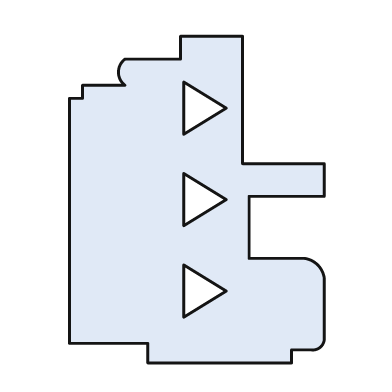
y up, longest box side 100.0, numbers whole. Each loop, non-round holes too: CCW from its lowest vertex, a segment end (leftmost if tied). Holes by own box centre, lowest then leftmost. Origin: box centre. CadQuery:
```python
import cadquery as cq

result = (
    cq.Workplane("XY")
    .moveTo(-15.0, -50.0)
    .lineTo(29.0, -50.0)
    .lineTo(29.0, -46.0)
    .lineTo(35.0, -46.0)
    .threePointArc((38.0, -45.0), (39.0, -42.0))
    .lineTo(39.0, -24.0)
    .threePointArc((37.0, -20.0), (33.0, -18.0))
    .lineTo(16.0, -18.0)
    .lineTo(16.0, 1.0)
    .lineTo(39.0, 1.0)
    .lineTo(39.0, 11.0)
    .lineTo(14.0, 11.0)
    .lineTo(14.0, 50.0)
    .lineTo(-5.0, 50.0)
    .lineTo(-5.0, 43.0)
    .lineTo(-22.0, 43.0)
    .threePointArc((-24.0, 39.0), (-22.0, 35.0))
    .lineTo(-35.0, 35.0)
    .lineTo(-35.0, 31.0)
    .lineTo(-39.0, 31.0)
    .lineTo(-39.0, -44.0)
    .lineTo(-15.0, -44.0)
    .close()
    .moveTo(-4.0, -36.0)
    .lineTo(9.0, -28.0)
    .lineTo(-4.0, -20.0)
    .close()
    .moveTo(-4.0, -8.0)
    .lineTo(9.0, 0.0)
    .lineTo(-4.0, 8.0)
    .close()
    .moveTo(-4.0, 20.0)
    .lineTo(9.0, 28.0)
    .lineTo(-4.0, 36.0)
    .close()
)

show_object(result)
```